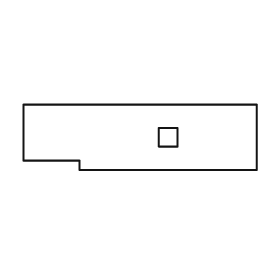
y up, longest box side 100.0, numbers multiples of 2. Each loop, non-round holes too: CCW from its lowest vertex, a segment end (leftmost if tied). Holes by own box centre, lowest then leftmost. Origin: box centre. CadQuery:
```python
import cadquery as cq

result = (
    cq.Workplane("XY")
    .moveTo(-26.0, -14.0)
    .lineTo(50.0, -14.0)
    .lineTo(50.0, 14.0)
    .lineTo(-50.0, 14.0)
    .lineTo(-50.0, -10.0)
    .lineTo(-26.0, -10.0)
    .close()
    .moveTo(8.0, -4.0)
    .lineTo(16.0, -4.0)
    .lineTo(16.0, 4.0)
    .lineTo(8.0, 4.0)
    .close()
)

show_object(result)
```